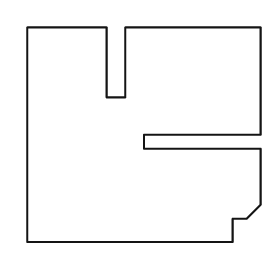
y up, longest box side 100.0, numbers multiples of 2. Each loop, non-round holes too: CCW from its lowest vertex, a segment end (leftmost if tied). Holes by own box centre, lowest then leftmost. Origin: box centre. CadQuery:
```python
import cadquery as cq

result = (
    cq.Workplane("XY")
    .moveTo(-50.0, -46.0)
    .lineTo(38.0, -46.0)
    .lineTo(38.0, -36.0)
    .lineTo(44.0, -36.0)
    .lineTo(50.0, -30.0)
    .lineTo(50.0, -6.0)
    .lineTo(0.0, -6.0)
    .lineTo(0.0, 0.0)
    .lineTo(50.0, 0.0)
    .lineTo(50.0, 46.0)
    .lineTo(-8.0, 46.0)
    .lineTo(-8.0, 16.0)
    .lineTo(-16.0, 16.0)
    .lineTo(-16.0, 46.0)
    .lineTo(-50.0, 46.0)
    .close()
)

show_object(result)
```